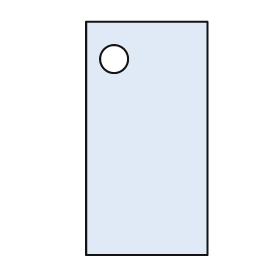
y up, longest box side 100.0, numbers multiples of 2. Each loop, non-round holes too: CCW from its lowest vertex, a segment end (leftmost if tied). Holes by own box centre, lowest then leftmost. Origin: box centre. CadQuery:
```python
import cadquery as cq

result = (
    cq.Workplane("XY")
    .moveTo(-26.0, -50.0)
    .lineTo(26.0, -50.0)
    .lineTo(26.0, 50.0)
    .lineTo(-26.0, 50.0)
    .close()
    .moveTo(-14.0, 34.0)
    .circle(6.0)
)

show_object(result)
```